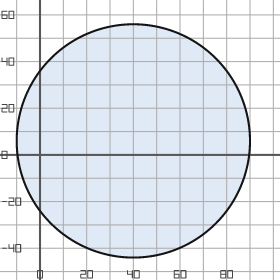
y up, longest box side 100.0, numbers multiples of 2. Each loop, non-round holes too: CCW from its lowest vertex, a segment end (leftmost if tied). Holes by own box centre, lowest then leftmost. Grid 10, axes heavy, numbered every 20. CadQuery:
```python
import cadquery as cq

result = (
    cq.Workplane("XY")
    .moveTo(40.0, 6.0)
    .circle(50.0)
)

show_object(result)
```